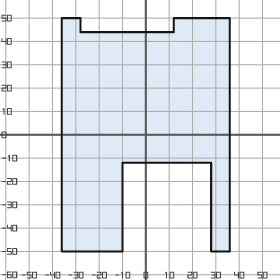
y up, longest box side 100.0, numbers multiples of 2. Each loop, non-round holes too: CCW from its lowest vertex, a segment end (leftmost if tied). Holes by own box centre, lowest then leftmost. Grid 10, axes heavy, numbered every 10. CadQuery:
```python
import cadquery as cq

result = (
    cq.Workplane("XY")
    .moveTo(-36.0, -50.0)
    .lineTo(-10.0, -50.0)
    .lineTo(-10.0, -12.0)
    .lineTo(28.0, -12.0)
    .lineTo(28.0, -50.0)
    .lineTo(36.0, -50.0)
    .lineTo(36.0, 50.0)
    .lineTo(12.0, 50.0)
    .lineTo(12.0, 44.0)
    .lineTo(-28.0, 44.0)
    .lineTo(-28.0, 50.0)
    .lineTo(-36.0, 50.0)
    .close()
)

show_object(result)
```